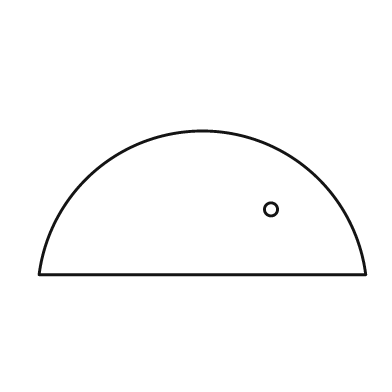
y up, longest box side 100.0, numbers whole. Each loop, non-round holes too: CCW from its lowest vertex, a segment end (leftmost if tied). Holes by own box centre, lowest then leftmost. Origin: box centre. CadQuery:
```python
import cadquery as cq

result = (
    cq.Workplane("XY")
    .moveTo(-50.0, -22.0)
    .lineTo(50.0, -22.0)
    .threePointArc((0.0, 22.0), (-50.0, -22.0))
    .close()
    .moveTo(21.0, -2.0)
    .circle(2.0)
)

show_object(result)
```